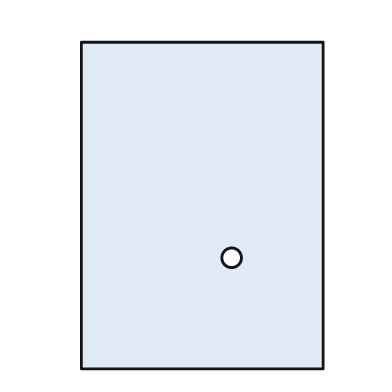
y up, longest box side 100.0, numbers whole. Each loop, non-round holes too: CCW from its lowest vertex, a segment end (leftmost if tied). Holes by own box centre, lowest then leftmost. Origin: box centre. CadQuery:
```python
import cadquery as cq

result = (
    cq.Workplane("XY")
    .moveTo(-37.0, -50.0)
    .lineTo(37.0, -50.0)
    .lineTo(37.0, 50.0)
    .lineTo(-37.0, 50.0)
    .close()
    .moveTo(9.0, -16.0)
    .circle(3.0)
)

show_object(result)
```